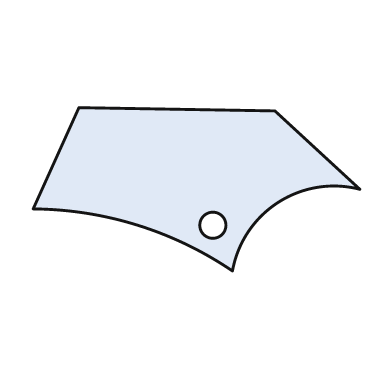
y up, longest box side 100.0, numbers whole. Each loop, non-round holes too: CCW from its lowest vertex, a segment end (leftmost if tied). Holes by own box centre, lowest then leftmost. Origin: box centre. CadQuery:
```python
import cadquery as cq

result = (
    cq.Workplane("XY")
    .moveTo(11.0, -25.0)
    .threePointArc((25.0, -4.0), (50.0, 0.0))
    .lineTo(24.0, 24.0)
    .lineTo(-36.0, 25.0)
    .lineTo(-50.0, -6.0)
    .threePointArc((-18.0, -11.0), (11.0, -25.0))
    .close()
    .moveTo(5.0, -11.0)
    .circle(4.0)
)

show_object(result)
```